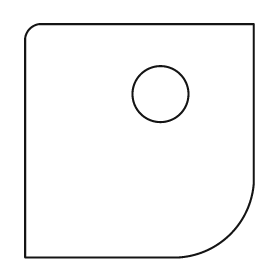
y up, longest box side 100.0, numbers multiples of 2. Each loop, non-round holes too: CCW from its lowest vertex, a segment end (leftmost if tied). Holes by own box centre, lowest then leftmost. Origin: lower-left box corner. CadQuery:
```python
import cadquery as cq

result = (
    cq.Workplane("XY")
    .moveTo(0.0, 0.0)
    .lineTo(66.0, 0.0)
    .threePointArc((88.0, 10.0), (98.0, 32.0))
    .lineTo(98.0, 100.0)
    .lineTo(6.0, 100.0)
    .threePointArc((2.0, 98.0), (0.0, 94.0))
    .close()
    .moveTo(58.0, 70.0)
    .circle(12.0)
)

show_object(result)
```